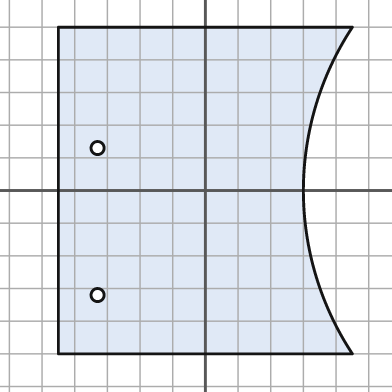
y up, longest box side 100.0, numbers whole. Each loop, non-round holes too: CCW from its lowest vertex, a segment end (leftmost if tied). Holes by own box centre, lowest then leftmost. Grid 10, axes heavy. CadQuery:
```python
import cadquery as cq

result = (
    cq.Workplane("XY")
    .moveTo(-45.0, -50.0)
    .lineTo(45.0, -50.0)
    .threePointArc((30.0, 0.0), (45.0, 50.0))
    .lineTo(-45.0, 50.0)
    .close()
    .moveTo(-33.0, -32.0)
    .circle(2.0)
    .moveTo(-33.0, 13.0)
    .circle(2.0)
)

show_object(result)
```